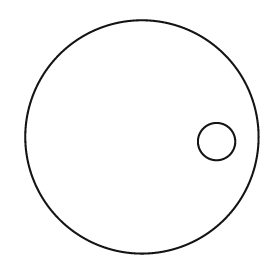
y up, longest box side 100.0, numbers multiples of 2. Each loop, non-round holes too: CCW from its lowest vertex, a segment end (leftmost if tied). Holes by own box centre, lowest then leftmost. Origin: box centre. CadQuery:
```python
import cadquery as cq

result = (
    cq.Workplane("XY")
    .moveTo(0.0, 0.0)
    .circle(50.0)
    .moveTo(32.0, -2.0)
    .circle(8.0)
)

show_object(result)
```